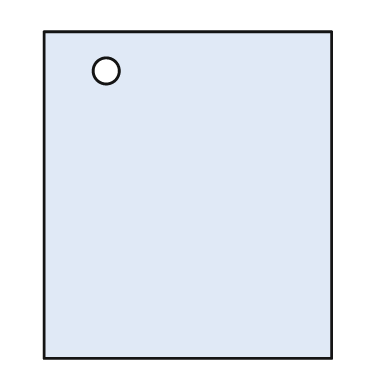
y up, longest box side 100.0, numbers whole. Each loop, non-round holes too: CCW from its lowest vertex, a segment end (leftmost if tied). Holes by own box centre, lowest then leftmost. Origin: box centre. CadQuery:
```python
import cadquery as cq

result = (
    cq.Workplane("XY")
    .moveTo(-44.0, -50.0)
    .lineTo(44.0, -50.0)
    .lineTo(44.0, 50.0)
    .lineTo(-44.0, 50.0)
    .close()
    .moveTo(-25.0, 38.0)
    .circle(4.0)
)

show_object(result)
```